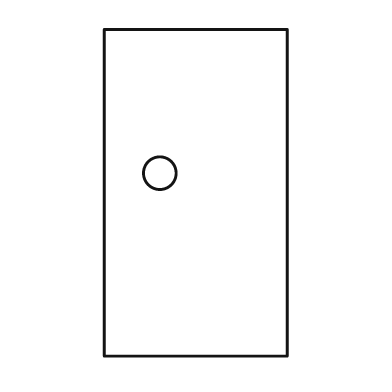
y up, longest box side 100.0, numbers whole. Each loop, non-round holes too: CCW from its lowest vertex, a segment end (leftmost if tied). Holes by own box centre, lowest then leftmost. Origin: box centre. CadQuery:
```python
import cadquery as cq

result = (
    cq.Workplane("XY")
    .moveTo(-28.0, -50.0)
    .lineTo(28.0, -50.0)
    .lineTo(28.0, 50.0)
    .lineTo(-28.0, 50.0)
    .close()
    .moveTo(-11.0, 6.0)
    .circle(5.0)
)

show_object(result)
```